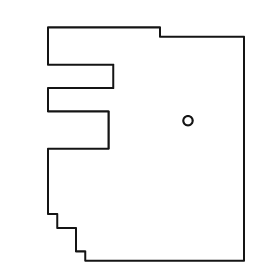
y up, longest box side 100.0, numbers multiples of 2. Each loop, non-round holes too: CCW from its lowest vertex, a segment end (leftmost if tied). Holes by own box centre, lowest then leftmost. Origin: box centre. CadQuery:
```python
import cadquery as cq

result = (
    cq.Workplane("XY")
    .moveTo(-26.0, -50.0)
    .lineTo(42.0, -50.0)
    .lineTo(42.0, 46.0)
    .lineTo(6.0, 46.0)
    .lineTo(6.0, 50.0)
    .lineTo(-42.0, 50.0)
    .lineTo(-42.0, 34.0)
    .lineTo(-14.0, 34.0)
    .lineTo(-14.0, 24.0)
    .lineTo(-42.0, 24.0)
    .lineTo(-42.0, 14.0)
    .lineTo(-16.0, 14.0)
    .lineTo(-16.0, -2.0)
    .lineTo(-42.0, -2.0)
    .lineTo(-42.0, -30.0)
    .lineTo(-38.0, -30.0)
    .lineTo(-38.0, -36.0)
    .lineTo(-30.0, -36.0)
    .lineTo(-30.0, -46.0)
    .lineTo(-26.0, -46.0)
    .close()
    .moveTo(18.0, 10.0)
    .circle(2.0)
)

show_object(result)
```